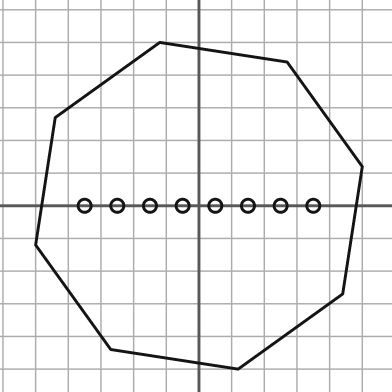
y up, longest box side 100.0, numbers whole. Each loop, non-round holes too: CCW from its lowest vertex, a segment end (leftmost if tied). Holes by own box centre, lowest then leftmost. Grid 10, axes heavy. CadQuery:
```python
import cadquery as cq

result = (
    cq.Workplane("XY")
    .moveTo(12.0, -50.0)
    .lineTo(44.0, -27.0)
    .lineTo(50.0, 12.0)
    .lineTo(27.0, 44.0)
    .lineTo(-12.0, 50.0)
    .lineTo(-44.0, 27.0)
    .lineTo(-50.0, -12.0)
    .lineTo(-27.0, -44.0)
    .close()
    .moveTo(-35.0, 0.0)
    .circle(2.0)
    .moveTo(-25.0, 0.0)
    .circle(2.0)
    .moveTo(-15.0, 0.0)
    .circle(2.0)
    .moveTo(-5.0, 0.0)
    .circle(2.0)
    .moveTo(5.0, 0.0)
    .circle(2.0)
    .moveTo(15.0, 0.0)
    .circle(2.0)
    .moveTo(25.0, 0.0)
    .circle(2.0)
    .moveTo(35.0, 0.0)
    .circle(2.0)
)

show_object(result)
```